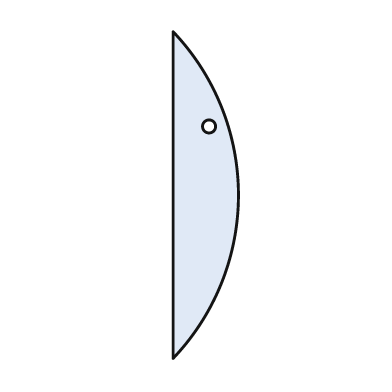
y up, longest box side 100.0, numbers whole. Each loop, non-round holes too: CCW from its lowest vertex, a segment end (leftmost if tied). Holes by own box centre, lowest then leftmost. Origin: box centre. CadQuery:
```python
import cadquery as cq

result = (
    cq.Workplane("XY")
    .moveTo(-10.0, -50.0)
    .threePointArc((10.0, 0.0), (-10.0, 50.0))
    .close()
    .moveTo(1.0, 21.0)
    .circle(2.0)
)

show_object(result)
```